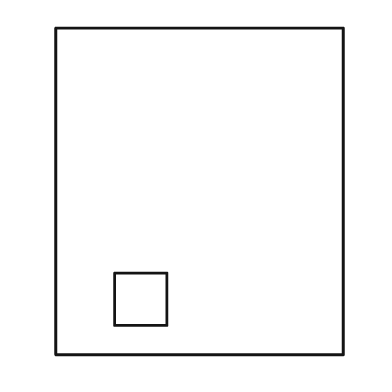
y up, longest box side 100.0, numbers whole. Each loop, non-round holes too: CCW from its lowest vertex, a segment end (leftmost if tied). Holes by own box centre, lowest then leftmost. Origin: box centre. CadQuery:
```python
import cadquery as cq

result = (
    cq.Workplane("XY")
    .moveTo(-44.0, -50.0)
    .lineTo(44.0, -50.0)
    .lineTo(44.0, 50.0)
    .lineTo(-44.0, 50.0)
    .close()
    .moveTo(-26.0, -41.0)
    .lineTo(-10.0, -41.0)
    .lineTo(-10.0, -25.0)
    .lineTo(-26.0, -25.0)
    .close()
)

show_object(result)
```